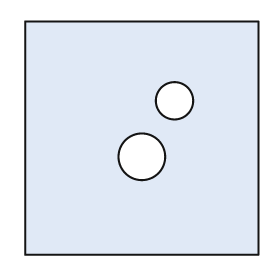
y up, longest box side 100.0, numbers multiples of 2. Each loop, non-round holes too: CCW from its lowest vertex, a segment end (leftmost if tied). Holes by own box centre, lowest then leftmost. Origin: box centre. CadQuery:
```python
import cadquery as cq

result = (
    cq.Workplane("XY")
    .moveTo(-50.0, -50.0)
    .lineTo(50.0, -50.0)
    .lineTo(50.0, 50.0)
    .lineTo(-50.0, 50.0)
    .close()
    .moveTo(0.0, -8.0)
    .circle(10.0)
    .moveTo(14.0, 16.0)
    .circle(8.0)
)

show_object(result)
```